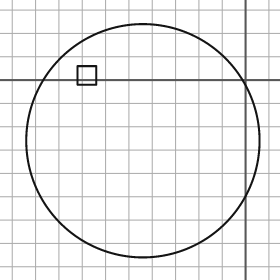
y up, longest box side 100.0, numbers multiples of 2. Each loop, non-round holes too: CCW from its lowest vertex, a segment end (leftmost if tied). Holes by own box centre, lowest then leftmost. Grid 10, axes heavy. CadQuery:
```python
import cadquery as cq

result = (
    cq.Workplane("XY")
    .moveTo(-44.0, -26.0)
    .circle(50.0)
    .moveTo(-72.0, -2.0)
    .lineTo(-64.0, -2.0)
    .lineTo(-64.0, 6.0)
    .lineTo(-72.0, 6.0)
    .close()
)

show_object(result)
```